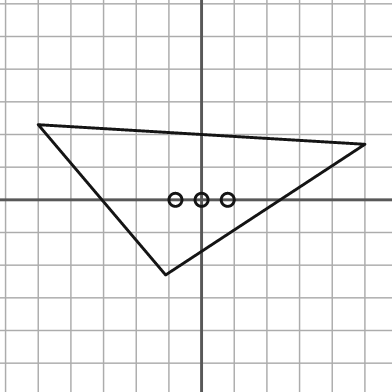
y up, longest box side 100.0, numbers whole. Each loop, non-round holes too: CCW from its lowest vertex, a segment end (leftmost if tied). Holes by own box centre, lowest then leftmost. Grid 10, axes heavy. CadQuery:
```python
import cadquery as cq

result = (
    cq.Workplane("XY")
    .moveTo(-11.0, -23.0)
    .lineTo(50.0, 17.0)
    .lineTo(-50.0, 23.0)
    .close()
    .moveTo(-8.0, 0.0)
    .circle(2.0)
    .moveTo(0.0, 0.0)
    .circle(2.0)
    .moveTo(8.0, 0.0)
    .circle(2.0)
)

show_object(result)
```